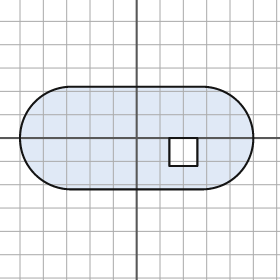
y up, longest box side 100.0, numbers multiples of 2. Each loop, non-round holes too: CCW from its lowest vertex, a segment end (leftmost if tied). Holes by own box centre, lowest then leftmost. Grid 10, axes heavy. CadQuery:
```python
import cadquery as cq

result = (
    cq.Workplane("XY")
    .moveTo(-28.0, -22.0)
    .lineTo(28.0, -22.0)
    .threePointArc((50.0, 0.0), (28.0, 22.0))
    .lineTo(-28.0, 22.0)
    .threePointArc((-50.0, 0.0), (-28.0, -22.0))
    .close()
    .moveTo(14.0, -12.0)
    .lineTo(26.0, -12.0)
    .lineTo(26.0, 0.0)
    .lineTo(14.0, 0.0)
    .close()
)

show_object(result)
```